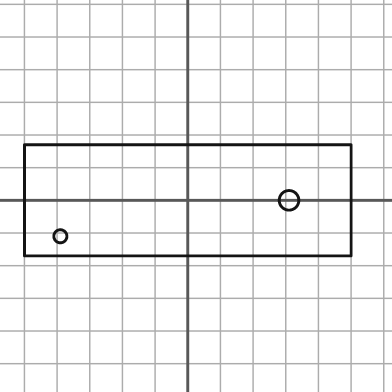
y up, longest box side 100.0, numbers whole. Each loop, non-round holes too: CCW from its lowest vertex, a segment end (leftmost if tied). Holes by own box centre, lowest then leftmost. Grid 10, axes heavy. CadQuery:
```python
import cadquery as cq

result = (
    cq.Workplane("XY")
    .moveTo(-50.0, -17.0)
    .lineTo(50.0, -17.0)
    .lineTo(50.0, 17.0)
    .lineTo(-50.0, 17.0)
    .close()
    .moveTo(-39.0, -11.0)
    .circle(2.0)
    .moveTo(31.0, 0.0)
    .circle(3.0)
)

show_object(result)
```